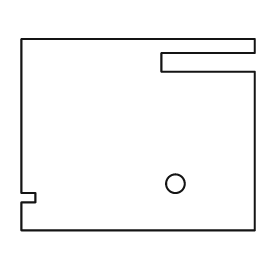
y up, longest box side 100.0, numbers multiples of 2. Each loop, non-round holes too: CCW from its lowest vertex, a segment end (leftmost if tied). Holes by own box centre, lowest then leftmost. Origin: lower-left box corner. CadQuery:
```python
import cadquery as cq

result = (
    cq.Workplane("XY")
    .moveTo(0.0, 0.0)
    .lineTo(100.0, 0.0)
    .lineTo(100.0, 68.0)
    .lineTo(60.0, 68.0)
    .lineTo(60.0, 76.0)
    .lineTo(100.0, 76.0)
    .lineTo(100.0, 82.0)
    .lineTo(0.0, 82.0)
    .lineTo(0.0, 16.0)
    .lineTo(6.0, 16.0)
    .lineTo(6.0, 12.0)
    .lineTo(0.0, 12.0)
    .close()
    .moveTo(66.0, 20.0)
    .circle(4.0)
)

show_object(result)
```